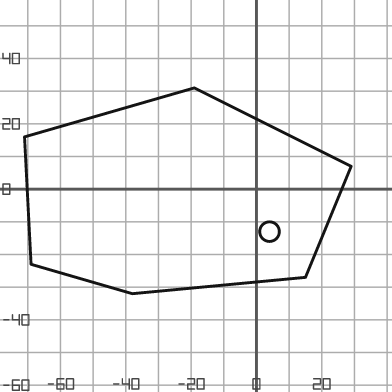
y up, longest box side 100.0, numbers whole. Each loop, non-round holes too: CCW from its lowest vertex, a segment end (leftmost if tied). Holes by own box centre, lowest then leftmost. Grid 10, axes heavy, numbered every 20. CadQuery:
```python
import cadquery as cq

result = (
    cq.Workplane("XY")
    .moveTo(-38.0, -32.0)
    .lineTo(15.0, -27.0)
    .lineTo(29.0, 7.0)
    .lineTo(-19.0, 31.0)
    .lineTo(-71.0, 16.0)
    .lineTo(-69.0, -23.0)
    .close()
    .moveTo(4.0, -13.0)
    .circle(3.0)
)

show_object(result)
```